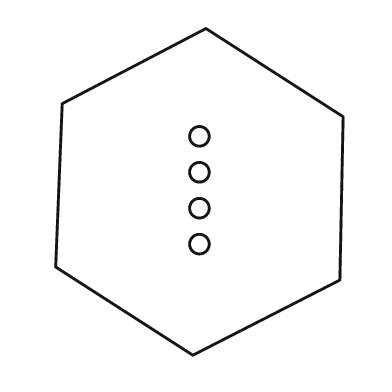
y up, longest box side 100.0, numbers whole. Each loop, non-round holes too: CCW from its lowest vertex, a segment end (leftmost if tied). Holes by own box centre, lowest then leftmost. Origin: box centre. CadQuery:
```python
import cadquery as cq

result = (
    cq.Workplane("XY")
    .moveTo(-2.0, -50.0)
    .lineTo(43.0, -27.0)
    .lineTo(44.0, 23.0)
    .lineTo(2.0, 50.0)
    .lineTo(-42.0, 27.0)
    .lineTo(-44.0, -23.0)
    .close()
    .moveTo(0.0, -16.0)
    .circle(3.0)
    .moveTo(0.0, -5.0)
    .circle(3.0)
    .moveTo(0.0, 6.0)
    .circle(3.0)
    .moveTo(0.0, 17.0)
    .circle(3.0)
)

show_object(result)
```